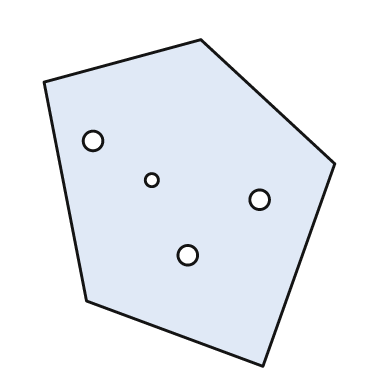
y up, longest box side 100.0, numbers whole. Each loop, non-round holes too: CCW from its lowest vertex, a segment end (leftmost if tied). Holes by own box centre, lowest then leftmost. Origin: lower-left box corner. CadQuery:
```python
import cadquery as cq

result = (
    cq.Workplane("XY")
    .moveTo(67.0, 0.0)
    .lineTo(89.0, 62.0)
    .lineTo(48.0, 100.0)
    .lineTo(0.0, 87.0)
    .lineTo(13.0, 20.0)
    .close()
    .moveTo(44.0, 34.0)
    .circle(3.0)
    .moveTo(66.0, 51.0)
    .circle(3.0)
    .moveTo(33.0, 57.0)
    .circle(2.0)
    .moveTo(15.0, 69.0)
    .circle(3.0)
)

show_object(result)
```